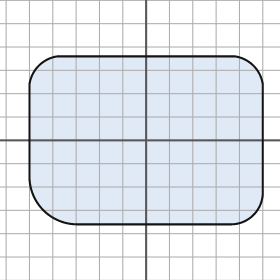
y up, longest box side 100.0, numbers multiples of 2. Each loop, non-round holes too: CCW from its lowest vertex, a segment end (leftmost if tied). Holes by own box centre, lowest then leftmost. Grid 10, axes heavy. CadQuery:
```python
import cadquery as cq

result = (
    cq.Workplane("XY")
    .moveTo(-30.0, -36.0)
    .lineTo(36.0, -36.0)
    .threePointArc((46.0, -32.0), (50.0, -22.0))
    .lineTo(50.0, 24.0)
    .threePointArc((46.0, 32.0), (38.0, 36.0))
    .lineTo(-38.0, 36.0)
    .threePointArc((-46.0, 32.0), (-50.0, 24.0))
    .lineTo(-50.0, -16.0)
    .threePointArc((-44.0, -30.0), (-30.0, -36.0))
    .close()
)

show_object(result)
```